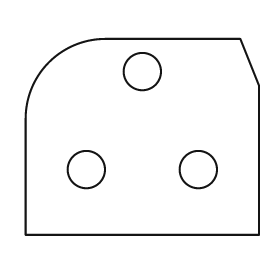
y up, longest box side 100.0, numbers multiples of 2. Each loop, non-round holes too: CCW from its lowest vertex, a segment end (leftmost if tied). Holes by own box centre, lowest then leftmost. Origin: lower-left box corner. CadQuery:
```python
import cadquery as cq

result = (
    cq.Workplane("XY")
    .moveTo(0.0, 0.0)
    .lineTo(100.0, 0.0)
    .lineTo(100.0, 64.0)
    .lineTo(92.0, 84.0)
    .lineTo(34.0, 84.0)
    .threePointArc((10.0, 74.0), (0.0, 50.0))
    .close()
    .moveTo(26.0, 28.0)
    .circle(8.0)
    .moveTo(74.0, 28.0)
    .circle(8.0)
    .moveTo(50.0, 70.0)
    .circle(8.0)
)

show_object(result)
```